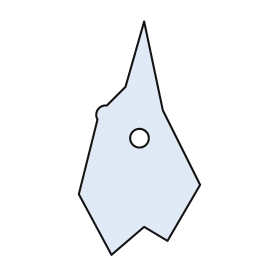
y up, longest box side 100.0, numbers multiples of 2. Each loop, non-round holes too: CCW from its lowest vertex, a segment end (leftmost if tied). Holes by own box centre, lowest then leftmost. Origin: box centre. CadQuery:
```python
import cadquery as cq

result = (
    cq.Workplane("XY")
    .moveTo(-12.0, -50.0)
    .lineTo(2.0, -38.0)
    .lineTo(12.0, -44.0)
    .lineTo(26.0, -20.0)
    .lineTo(10.0, 12.0)
    .lineTo(2.0, 50.0)
    .lineTo(-6.0, 22.0)
    .lineTo(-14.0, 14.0)
    .threePointArc((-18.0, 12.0), (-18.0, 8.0))
    .lineTo(-26.0, -24.0)
    .close()
    .moveTo(0.0, 0.0)
    .circle(4.0)
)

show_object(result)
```